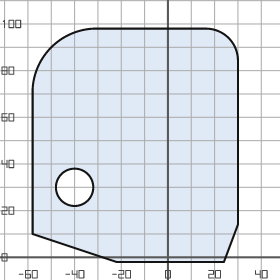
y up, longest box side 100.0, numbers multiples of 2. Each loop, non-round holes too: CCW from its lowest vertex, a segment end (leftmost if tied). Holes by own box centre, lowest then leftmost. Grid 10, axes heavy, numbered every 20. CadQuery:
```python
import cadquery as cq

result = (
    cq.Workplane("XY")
    .moveTo(-22.0, -2.0)
    .lineTo(24.0, -2.0)
    .lineTo(30.0, 14.0)
    .lineTo(30.0, 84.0)
    .threePointArc((26.0, 94.0), (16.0, 98.0))
    .lineTo(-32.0, 98.0)
    .threePointArc((-50.0, 90.0), (-58.0, 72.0))
    .lineTo(-58.0, 10.0)
    .close()
    .moveTo(-40.0, 30.0)
    .circle(8.0)
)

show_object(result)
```